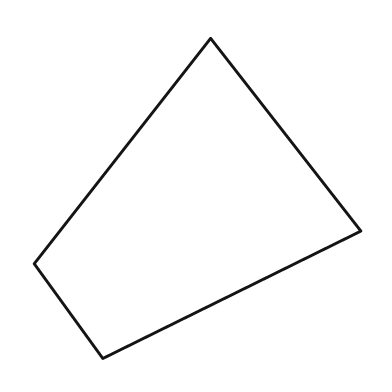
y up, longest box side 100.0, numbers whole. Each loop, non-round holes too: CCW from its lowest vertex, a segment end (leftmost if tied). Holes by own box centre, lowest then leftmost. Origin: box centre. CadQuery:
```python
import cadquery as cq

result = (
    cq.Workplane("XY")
    .moveTo(-29.0, -49.0)
    .lineTo(50.0, -10.0)
    .lineTo(4.0, 49.0)
    .lineTo(-50.0, -20.0)
    .close()
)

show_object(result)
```